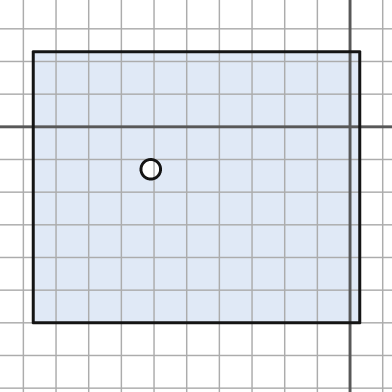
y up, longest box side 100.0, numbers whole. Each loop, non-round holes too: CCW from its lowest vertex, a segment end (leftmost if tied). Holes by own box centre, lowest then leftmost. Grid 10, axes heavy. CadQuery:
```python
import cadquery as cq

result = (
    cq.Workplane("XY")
    .moveTo(-97.0, -60.0)
    .lineTo(3.0, -60.0)
    .lineTo(3.0, 23.0)
    .lineTo(-97.0, 23.0)
    .close()
    .moveTo(-61.0, -13.0)
    .circle(3.0)
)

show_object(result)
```